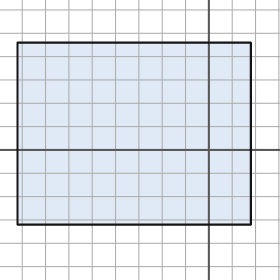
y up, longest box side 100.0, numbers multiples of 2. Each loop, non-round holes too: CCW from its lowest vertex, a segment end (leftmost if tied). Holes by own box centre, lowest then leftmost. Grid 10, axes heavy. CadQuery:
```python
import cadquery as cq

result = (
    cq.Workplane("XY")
    .moveTo(-82.0, -32.0)
    .lineTo(18.0, -32.0)
    .lineTo(18.0, 46.0)
    .lineTo(-82.0, 46.0)
    .close()
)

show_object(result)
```